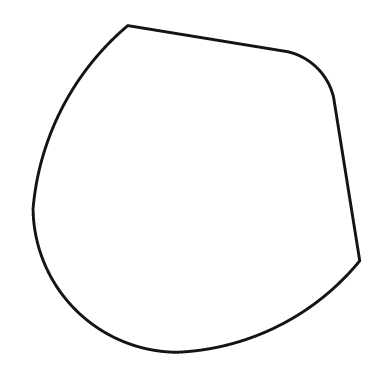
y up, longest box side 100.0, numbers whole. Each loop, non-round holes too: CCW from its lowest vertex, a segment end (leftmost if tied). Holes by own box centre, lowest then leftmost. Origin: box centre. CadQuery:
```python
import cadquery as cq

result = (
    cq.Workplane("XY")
    .moveTo(-6.0, -50.0)
    .threePointArc((25.0, -42.0), (50.0, -22.0))
    .lineTo(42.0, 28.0)
    .threePointArc((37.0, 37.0), (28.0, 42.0))
    .lineTo(-21.0, 50.0)
    .threePointArc((-41.0, 25.0), (-50.0, -6.0))
    .threePointArc((-37.0, -37.0), (-6.0, -50.0))
    .close()
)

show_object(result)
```